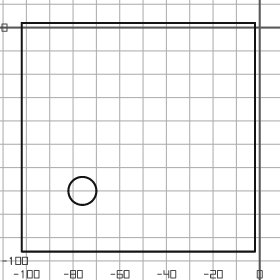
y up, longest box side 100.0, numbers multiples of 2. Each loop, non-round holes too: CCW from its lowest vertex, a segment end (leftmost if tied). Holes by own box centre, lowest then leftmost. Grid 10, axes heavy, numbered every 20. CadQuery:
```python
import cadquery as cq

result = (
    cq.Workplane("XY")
    .moveTo(-102.0, -96.0)
    .lineTo(-2.0, -96.0)
    .lineTo(-2.0, 2.0)
    .lineTo(-102.0, 2.0)
    .close()
    .moveTo(-76.0, -70.0)
    .circle(6.0)
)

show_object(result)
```